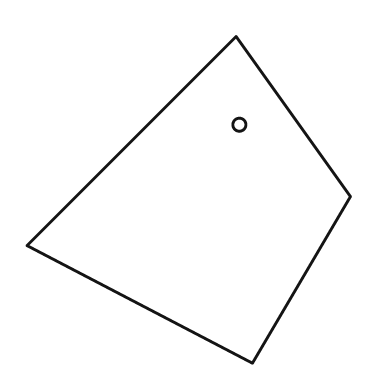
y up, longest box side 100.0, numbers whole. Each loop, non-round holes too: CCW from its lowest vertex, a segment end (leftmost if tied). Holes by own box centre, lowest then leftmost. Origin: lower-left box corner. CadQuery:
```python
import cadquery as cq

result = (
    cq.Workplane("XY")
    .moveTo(69.0, 0.0)
    .lineTo(99.0, 51.0)
    .lineTo(64.0, 100.0)
    .lineTo(0.0, 36.0)
    .close()
    .moveTo(65.0, 73.0)
    .circle(2.0)
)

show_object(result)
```